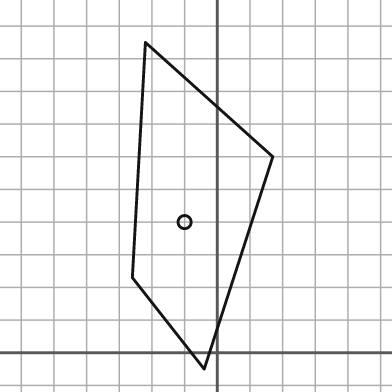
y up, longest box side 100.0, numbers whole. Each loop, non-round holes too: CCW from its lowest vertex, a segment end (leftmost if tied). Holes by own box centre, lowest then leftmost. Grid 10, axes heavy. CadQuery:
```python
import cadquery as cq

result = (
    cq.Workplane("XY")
    .moveTo(-4.0, -5.0)
    .lineTo(17.0, 60.0)
    .lineTo(-22.0, 95.0)
    .lineTo(-26.0, 23.0)
    .close()
    .moveTo(-10.0, 40.0)
    .circle(2.0)
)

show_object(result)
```